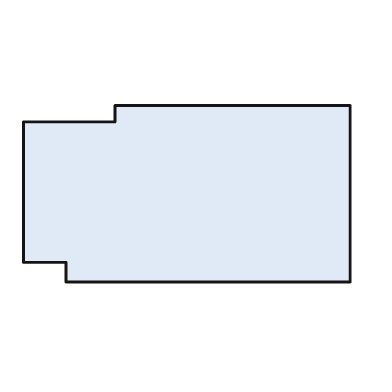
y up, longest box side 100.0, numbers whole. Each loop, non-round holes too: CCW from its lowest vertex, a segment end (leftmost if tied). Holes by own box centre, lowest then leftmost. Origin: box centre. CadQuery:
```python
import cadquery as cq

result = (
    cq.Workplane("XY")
    .moveTo(-37.0, -27.0)
    .lineTo(50.0, -27.0)
    .lineTo(50.0, 27.0)
    .lineTo(-22.0, 27.0)
    .lineTo(-22.0, 22.0)
    .lineTo(-50.0, 22.0)
    .lineTo(-50.0, -21.0)
    .lineTo(-37.0, -21.0)
    .close()
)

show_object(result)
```